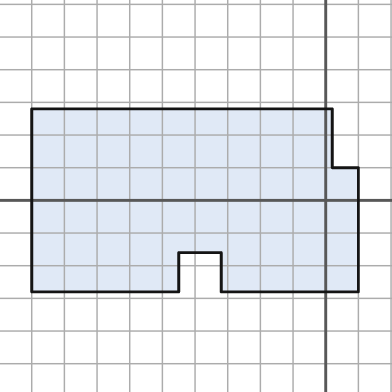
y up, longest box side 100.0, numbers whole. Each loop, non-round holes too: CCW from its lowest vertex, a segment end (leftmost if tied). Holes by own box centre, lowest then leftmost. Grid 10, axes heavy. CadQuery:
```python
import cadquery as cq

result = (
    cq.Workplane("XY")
    .moveTo(-90.0, -28.0)
    .lineTo(-45.0, -28.0)
    .lineTo(-45.0, -16.0)
    .lineTo(-32.0, -16.0)
    .lineTo(-32.0, -28.0)
    .lineTo(10.0, -28.0)
    .lineTo(10.0, 10.0)
    .lineTo(2.0, 10.0)
    .lineTo(2.0, 28.0)
    .lineTo(-90.0, 28.0)
    .close()
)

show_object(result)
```